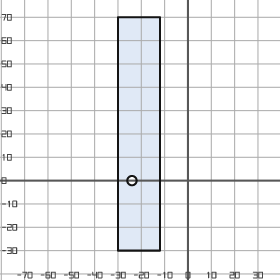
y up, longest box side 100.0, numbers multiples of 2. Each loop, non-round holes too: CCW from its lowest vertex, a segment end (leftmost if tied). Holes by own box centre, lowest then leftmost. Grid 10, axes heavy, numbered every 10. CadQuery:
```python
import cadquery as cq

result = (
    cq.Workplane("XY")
    .moveTo(-30.0, -30.0)
    .lineTo(-12.0, -30.0)
    .lineTo(-12.0, 70.0)
    .lineTo(-30.0, 70.0)
    .close()
    .moveTo(-24.0, 0.0)
    .circle(2.0)
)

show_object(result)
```